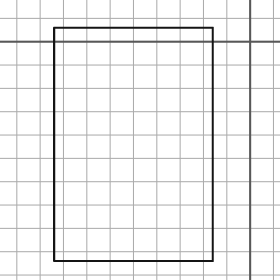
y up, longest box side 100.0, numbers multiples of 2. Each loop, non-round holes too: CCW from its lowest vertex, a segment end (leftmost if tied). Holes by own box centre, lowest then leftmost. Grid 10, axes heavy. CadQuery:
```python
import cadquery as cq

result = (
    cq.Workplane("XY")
    .moveTo(-84.0, -94.0)
    .lineTo(-16.0, -94.0)
    .lineTo(-16.0, 6.0)
    .lineTo(-84.0, 6.0)
    .close()
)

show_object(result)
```